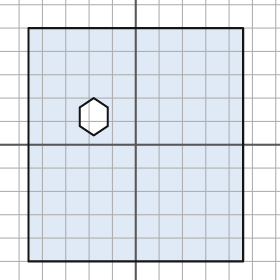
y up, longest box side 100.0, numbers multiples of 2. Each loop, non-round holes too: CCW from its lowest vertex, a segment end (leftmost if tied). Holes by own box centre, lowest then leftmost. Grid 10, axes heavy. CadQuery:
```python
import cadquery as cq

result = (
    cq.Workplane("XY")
    .moveTo(-46.0, -50.0)
    .lineTo(46.0, -50.0)
    .lineTo(46.0, 50.0)
    .lineTo(-46.0, 50.0)
    .close()
    .moveTo(-18.0, 4.0)
    .lineTo(-12.0, 8.0)
    .lineTo(-12.0, 16.0)
    .lineTo(-18.0, 20.0)
    .lineTo(-24.0, 16.0)
    .lineTo(-24.0, 8.0)
    .close()
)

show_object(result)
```